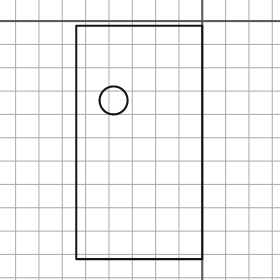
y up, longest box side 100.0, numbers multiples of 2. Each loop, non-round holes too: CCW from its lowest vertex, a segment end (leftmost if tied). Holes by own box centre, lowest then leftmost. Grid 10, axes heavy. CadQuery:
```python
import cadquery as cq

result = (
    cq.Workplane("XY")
    .moveTo(-54.0, -102.0)
    .lineTo(0.0, -102.0)
    .lineTo(0.0, -2.0)
    .lineTo(-54.0, -2.0)
    .close()
    .moveTo(-38.0, -34.0)
    .circle(6.0)
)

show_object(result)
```